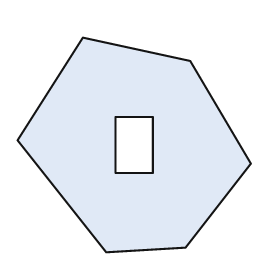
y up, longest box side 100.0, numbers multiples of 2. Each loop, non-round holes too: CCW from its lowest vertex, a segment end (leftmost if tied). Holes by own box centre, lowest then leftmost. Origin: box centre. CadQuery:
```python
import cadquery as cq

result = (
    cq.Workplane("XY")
    .moveTo(-12.0, -46.0)
    .lineTo(22.0, -44.0)
    .lineTo(50.0, -8.0)
    .lineTo(24.0, 36.0)
    .lineTo(-22.0, 46.0)
    .lineTo(-50.0, 2.0)
    .close()
    .moveTo(-8.0, -12.0)
    .lineTo(8.0, -12.0)
    .lineTo(8.0, 12.0)
    .lineTo(-8.0, 12.0)
    .close()
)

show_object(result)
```